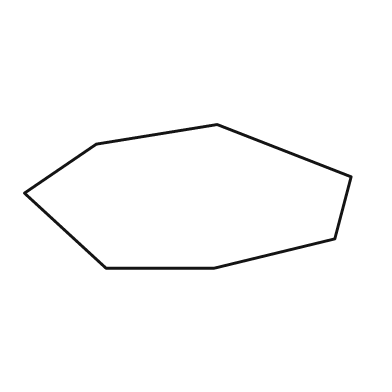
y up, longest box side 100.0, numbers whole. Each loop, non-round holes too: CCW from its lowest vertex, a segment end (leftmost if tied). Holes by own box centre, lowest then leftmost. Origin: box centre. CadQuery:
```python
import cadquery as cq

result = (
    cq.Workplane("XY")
    .moveTo(-25.0, -22.0)
    .lineTo(8.0, -22.0)
    .lineTo(45.0, -13.0)
    .lineTo(50.0, 6.0)
    .lineTo(9.0, 22.0)
    .lineTo(-28.0, 16.0)
    .lineTo(-50.0, 1.0)
    .close()
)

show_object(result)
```